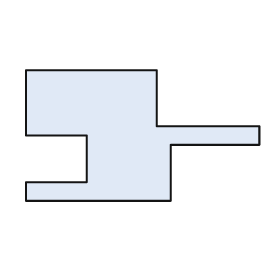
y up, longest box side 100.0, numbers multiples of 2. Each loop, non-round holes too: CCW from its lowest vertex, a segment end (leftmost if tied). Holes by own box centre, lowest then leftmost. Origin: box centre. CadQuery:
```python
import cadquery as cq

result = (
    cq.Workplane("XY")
    .moveTo(-50.0, -28.0)
    .lineTo(12.0, -28.0)
    .lineTo(12.0, -4.0)
    .lineTo(50.0, -4.0)
    .lineTo(50.0, 4.0)
    .lineTo(6.0, 4.0)
    .lineTo(6.0, 28.0)
    .lineTo(-50.0, 28.0)
    .lineTo(-50.0, 0.0)
    .lineTo(-24.0, 0.0)
    .lineTo(-24.0, -20.0)
    .lineTo(-50.0, -20.0)
    .close()
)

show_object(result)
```